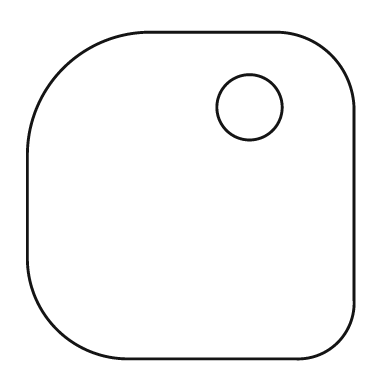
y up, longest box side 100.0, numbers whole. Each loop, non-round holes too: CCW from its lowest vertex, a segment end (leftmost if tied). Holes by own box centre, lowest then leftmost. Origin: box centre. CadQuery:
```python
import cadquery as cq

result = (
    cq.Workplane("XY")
    .moveTo(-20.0, -50.0)
    .lineTo(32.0, -50.0)
    .threePointArc((45.0, -45.0), (50.0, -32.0))
    .lineTo(50.0, 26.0)
    .threePointArc((43.0, 43.0), (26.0, 50.0))
    .lineTo(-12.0, 50.0)
    .threePointArc((-39.0, 39.0), (-50.0, 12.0))
    .lineTo(-50.0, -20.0)
    .threePointArc((-41.0, -41.0), (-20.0, -50.0))
    .close()
    .moveTo(18.0, 27.0)
    .circle(10.0)
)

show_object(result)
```